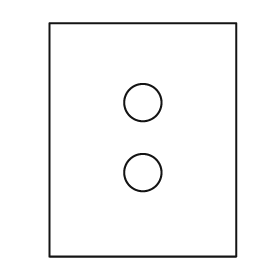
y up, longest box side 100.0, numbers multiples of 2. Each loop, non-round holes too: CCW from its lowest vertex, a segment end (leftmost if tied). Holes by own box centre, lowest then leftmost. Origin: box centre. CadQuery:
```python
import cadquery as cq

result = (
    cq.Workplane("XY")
    .moveTo(-40.0, -50.0)
    .lineTo(40.0, -50.0)
    .lineTo(40.0, 50.0)
    .lineTo(-40.0, 50.0)
    .close()
    .moveTo(0.0, -14.0)
    .circle(8.0)
    .moveTo(0.0, 16.0)
    .circle(8.0)
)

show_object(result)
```